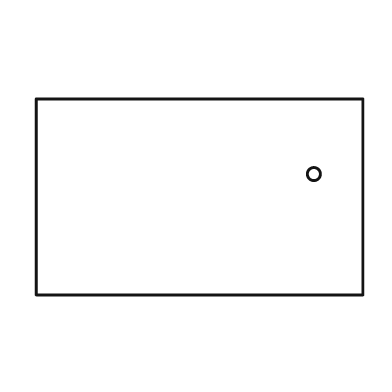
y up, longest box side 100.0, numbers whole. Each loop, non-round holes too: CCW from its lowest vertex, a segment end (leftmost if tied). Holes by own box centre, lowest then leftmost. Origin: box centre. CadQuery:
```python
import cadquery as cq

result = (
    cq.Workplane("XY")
    .moveTo(-50.0, -30.0)
    .lineTo(50.0, -30.0)
    .lineTo(50.0, 30.0)
    .lineTo(-50.0, 30.0)
    .close()
    .moveTo(35.0, 7.0)
    .circle(2.0)
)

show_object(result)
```